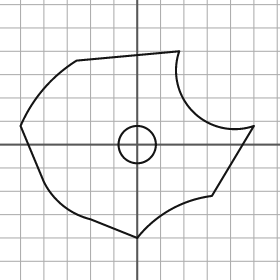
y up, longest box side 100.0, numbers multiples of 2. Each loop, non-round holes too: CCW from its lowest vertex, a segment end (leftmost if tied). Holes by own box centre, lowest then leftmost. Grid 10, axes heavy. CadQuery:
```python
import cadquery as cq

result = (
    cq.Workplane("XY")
    .moveTo(0.0, -40.0)
    .threePointArc((14.0, -28.0), (32.0, -22.0))
    .lineTo(50.0, 8.0)
    .threePointArc((24.0, 14.0), (18.0, 40.0))
    .lineTo(-26.0, 36.0)
    .threePointArc((-40.0, 24.0), (-50.0, 8.0))
    .lineTo(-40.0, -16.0)
    .threePointArc((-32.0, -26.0), (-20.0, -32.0))
    .close()
    .moveTo(0.0, 0.0)
    .circle(8.0)
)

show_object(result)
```